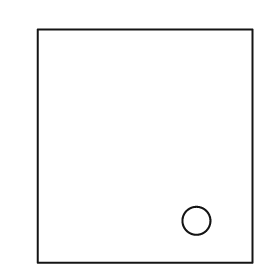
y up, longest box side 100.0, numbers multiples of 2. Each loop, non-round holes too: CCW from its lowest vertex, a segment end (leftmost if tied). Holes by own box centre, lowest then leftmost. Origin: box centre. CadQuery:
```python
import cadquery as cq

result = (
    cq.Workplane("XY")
    .moveTo(-46.0, -50.0)
    .lineTo(46.0, -50.0)
    .lineTo(46.0, 50.0)
    .lineTo(-46.0, 50.0)
    .close()
    .moveTo(22.0, -32.0)
    .circle(6.0)
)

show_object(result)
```